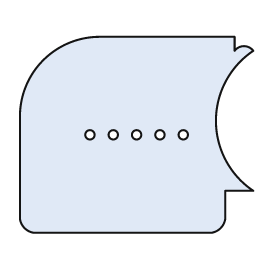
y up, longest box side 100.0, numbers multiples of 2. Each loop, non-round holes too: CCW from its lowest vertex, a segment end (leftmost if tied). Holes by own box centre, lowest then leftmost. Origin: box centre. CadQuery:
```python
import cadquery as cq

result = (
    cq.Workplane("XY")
    .moveTo(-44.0, -42.0)
    .lineTo(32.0, -42.0)
    .threePointArc((36.0, -40.0), (38.0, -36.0))
    .lineTo(38.0, -24.0)
    .lineTo(50.0, -24.0)
    .threePointArc((34.0, 6.0), (50.0, 36.0))
    .threePointArc((46.0, 38.0), (42.0, 36.0))
    .lineTo(42.0, 42.0)
    .lineTo(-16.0, 42.0)
    .threePointArc((-40.0, 32.0), (-50.0, 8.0))
    .lineTo(-50.0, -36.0)
    .threePointArc((-48.0, -40.0), (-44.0, -42.0))
    .close()
    .moveTo(-20.0, 0.0)
    .circle(2.0)
    .moveTo(-10.0, 0.0)
    .circle(2.0)
    .moveTo(0.0, 0.0)
    .circle(2.0)
    .moveTo(10.0, 0.0)
    .circle(2.0)
    .moveTo(20.0, 0.0)
    .circle(2.0)
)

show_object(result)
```